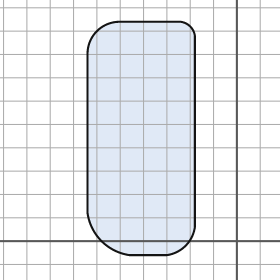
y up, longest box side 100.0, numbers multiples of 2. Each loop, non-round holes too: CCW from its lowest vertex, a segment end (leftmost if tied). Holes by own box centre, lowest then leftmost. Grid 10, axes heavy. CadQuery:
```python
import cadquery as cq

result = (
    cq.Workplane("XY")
    .moveTo(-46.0, -6.0)
    .lineTo(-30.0, -6.0)
    .threePointArc((-22.0, -2.0), (-18.0, 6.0))
    .lineTo(-18.0, 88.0)
    .threePointArc((-20.0, 92.0), (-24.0, 94.0))
    .lineTo(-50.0, 94.0)
    .threePointArc((-60.0, 90.0), (-64.0, 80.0))
    .lineTo(-64.0, 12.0)
    .threePointArc((-58.0, 0.0), (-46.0, -6.0))
    .close()
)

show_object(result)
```